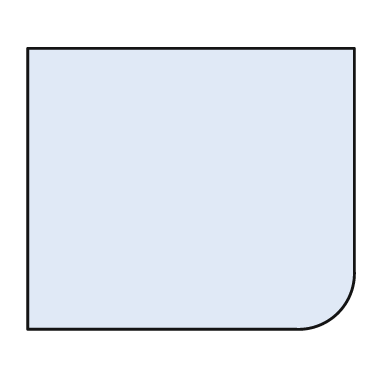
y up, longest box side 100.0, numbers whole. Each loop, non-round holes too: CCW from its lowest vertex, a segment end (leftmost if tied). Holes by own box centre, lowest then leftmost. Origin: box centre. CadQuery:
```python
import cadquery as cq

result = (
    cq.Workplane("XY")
    .moveTo(-50.0, -43.0)
    .lineTo(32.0, -43.0)
    .threePointArc((45.0, -38.0), (50.0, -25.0))
    .lineTo(50.0, 43.0)
    .lineTo(-50.0, 43.0)
    .close()
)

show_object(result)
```